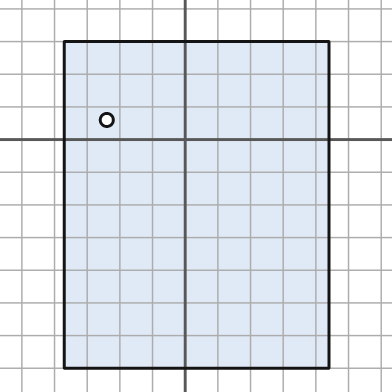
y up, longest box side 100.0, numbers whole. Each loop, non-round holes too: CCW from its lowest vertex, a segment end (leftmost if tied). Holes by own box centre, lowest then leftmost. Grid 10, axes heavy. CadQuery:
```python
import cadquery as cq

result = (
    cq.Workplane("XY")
    .moveTo(-37.0, -70.0)
    .lineTo(44.0, -70.0)
    .lineTo(44.0, 30.0)
    .lineTo(-37.0, 30.0)
    .close()
    .moveTo(-24.0, 6.0)
    .circle(2.0)
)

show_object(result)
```